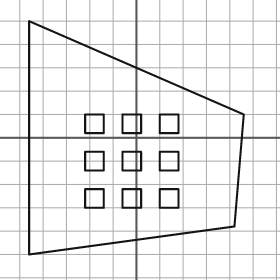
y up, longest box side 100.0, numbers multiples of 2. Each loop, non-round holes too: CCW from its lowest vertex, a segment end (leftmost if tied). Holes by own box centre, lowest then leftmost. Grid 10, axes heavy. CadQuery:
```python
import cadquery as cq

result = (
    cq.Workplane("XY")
    .moveTo(-46.0, -50.0)
    .lineTo(42.0, -38.0)
    .lineTo(46.0, 10.0)
    .lineTo(-46.0, 50.0)
    .close()
    .moveTo(-22.0, -30.0)
    .lineTo(-14.0, -30.0)
    .lineTo(-14.0, -22.0)
    .lineTo(-22.0, -22.0)
    .close()
    .moveTo(-6.0, -30.0)
    .lineTo(2.0, -30.0)
    .lineTo(2.0, -22.0)
    .lineTo(-6.0, -22.0)
    .close()
    .moveTo(10.0, -30.0)
    .lineTo(18.0, -30.0)
    .lineTo(18.0, -22.0)
    .lineTo(10.0, -22.0)
    .close()
    .moveTo(-22.0, -14.0)
    .lineTo(-14.0, -14.0)
    .lineTo(-14.0, -6.0)
    .lineTo(-22.0, -6.0)
    .close()
    .moveTo(-6.0, -14.0)
    .lineTo(2.0, -14.0)
    .lineTo(2.0, -6.0)
    .lineTo(-6.0, -6.0)
    .close()
    .moveTo(10.0, -14.0)
    .lineTo(18.0, -14.0)
    .lineTo(18.0, -6.0)
    .lineTo(10.0, -6.0)
    .close()
    .moveTo(-22.0, 2.0)
    .lineTo(-14.0, 2.0)
    .lineTo(-14.0, 10.0)
    .lineTo(-22.0, 10.0)
    .close()
    .moveTo(-6.0, 2.0)
    .lineTo(2.0, 2.0)
    .lineTo(2.0, 10.0)
    .lineTo(-6.0, 10.0)
    .close()
    .moveTo(10.0, 2.0)
    .lineTo(18.0, 2.0)
    .lineTo(18.0, 10.0)
    .lineTo(10.0, 10.0)
    .close()
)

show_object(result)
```